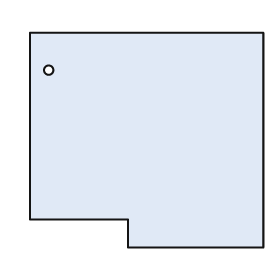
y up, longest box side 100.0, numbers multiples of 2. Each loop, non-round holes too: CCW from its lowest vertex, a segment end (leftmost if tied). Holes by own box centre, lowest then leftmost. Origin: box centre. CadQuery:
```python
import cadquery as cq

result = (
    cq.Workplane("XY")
    .moveTo(-8.0, -46.0)
    .lineTo(50.0, -46.0)
    .lineTo(50.0, 46.0)
    .lineTo(-50.0, 46.0)
    .lineTo(-50.0, -34.0)
    .lineTo(-8.0, -34.0)
    .close()
    .moveTo(-42.0, 30.0)
    .circle(2.0)
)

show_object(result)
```